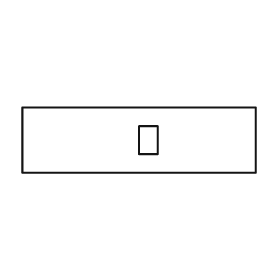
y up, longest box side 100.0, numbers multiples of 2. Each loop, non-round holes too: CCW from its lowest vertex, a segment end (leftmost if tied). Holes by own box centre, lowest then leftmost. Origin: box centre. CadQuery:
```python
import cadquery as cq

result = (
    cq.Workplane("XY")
    .moveTo(-50.0, -14.0)
    .lineTo(50.0, -14.0)
    .lineTo(50.0, 14.0)
    .lineTo(-50.0, 14.0)
    .close()
    .moveTo(0.0, -6.0)
    .lineTo(8.0, -6.0)
    .lineTo(8.0, 6.0)
    .lineTo(0.0, 6.0)
    .close()
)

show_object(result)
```